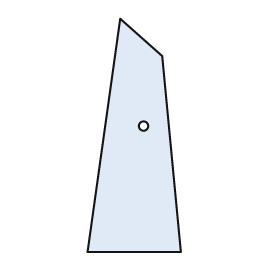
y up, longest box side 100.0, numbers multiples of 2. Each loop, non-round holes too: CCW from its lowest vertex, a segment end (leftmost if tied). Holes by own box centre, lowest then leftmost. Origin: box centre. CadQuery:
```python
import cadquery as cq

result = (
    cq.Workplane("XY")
    .moveTo(-20.0, -50.0)
    .lineTo(20.0, -50.0)
    .lineTo(12.0, 34.0)
    .lineTo(-6.0, 50.0)
    .close()
    .moveTo(4.0, 4.0)
    .circle(2.0)
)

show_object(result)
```